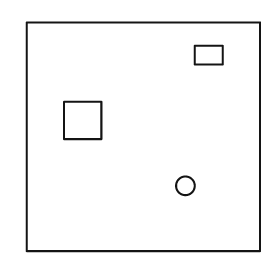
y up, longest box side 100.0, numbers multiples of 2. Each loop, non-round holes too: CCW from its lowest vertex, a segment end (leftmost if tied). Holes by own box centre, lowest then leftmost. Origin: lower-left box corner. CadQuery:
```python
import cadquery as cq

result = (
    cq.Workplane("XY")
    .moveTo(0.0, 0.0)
    .lineTo(100.0, 0.0)
    .lineTo(100.0, 98.0)
    .lineTo(0.0, 98.0)
    .close()
    .moveTo(68.0, 28.0)
    .circle(4.0)
    .moveTo(16.0, 48.0)
    .lineTo(32.0, 48.0)
    .lineTo(32.0, 64.0)
    .lineTo(16.0, 64.0)
    .close()
    .moveTo(72.0, 80.0)
    .lineTo(84.0, 80.0)
    .lineTo(84.0, 88.0)
    .lineTo(72.0, 88.0)
    .close()
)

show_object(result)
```